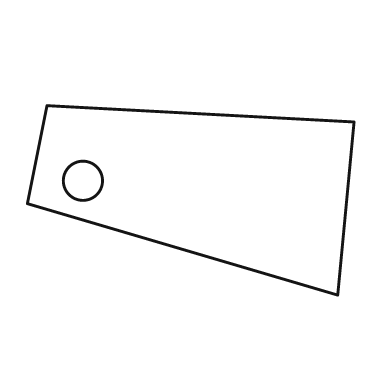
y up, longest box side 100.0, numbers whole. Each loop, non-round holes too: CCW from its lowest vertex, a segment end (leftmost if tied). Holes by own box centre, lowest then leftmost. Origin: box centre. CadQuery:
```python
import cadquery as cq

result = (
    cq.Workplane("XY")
    .moveTo(45.0, -29.0)
    .lineTo(50.0, 24.0)
    .lineTo(-44.0, 29.0)
    .lineTo(-50.0, -1.0)
    .close()
    .moveTo(-33.0, 6.0)
    .circle(6.0)
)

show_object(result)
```